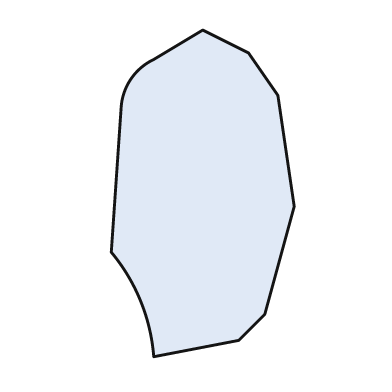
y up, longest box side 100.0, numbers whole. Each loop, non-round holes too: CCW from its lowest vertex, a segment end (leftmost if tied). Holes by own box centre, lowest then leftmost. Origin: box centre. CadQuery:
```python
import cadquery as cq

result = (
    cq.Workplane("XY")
    .moveTo(-15.0, -50.0)
    .lineTo(11.0, -45.0)
    .lineTo(19.0, -37.0)
    .lineTo(28.0, -4.0)
    .lineTo(23.0, 30.0)
    .lineTo(14.0, 43.0)
    .lineTo(0.0, 50.0)
    .lineTo(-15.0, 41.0)
    .threePointArc((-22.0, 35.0), (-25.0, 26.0))
    .lineTo(-28.0, -18.0)
    .threePointArc((-19.0, -33.0), (-15.0, -50.0))
    .close()
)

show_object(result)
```